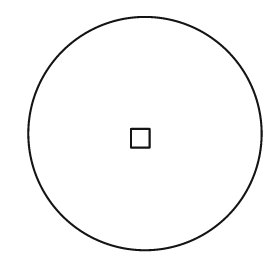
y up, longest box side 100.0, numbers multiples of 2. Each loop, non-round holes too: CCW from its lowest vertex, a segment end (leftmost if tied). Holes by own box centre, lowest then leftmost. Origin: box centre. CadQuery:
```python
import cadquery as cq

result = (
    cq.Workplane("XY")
    .moveTo(0.0, 0.0)
    .circle(50.0)
    .moveTo(-6.0, -6.0)
    .lineTo(2.0, -6.0)
    .lineTo(2.0, 2.0)
    .lineTo(-6.0, 2.0)
    .close()
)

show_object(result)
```